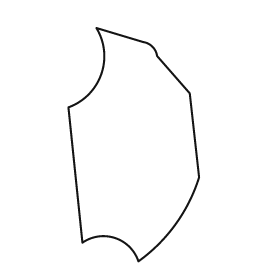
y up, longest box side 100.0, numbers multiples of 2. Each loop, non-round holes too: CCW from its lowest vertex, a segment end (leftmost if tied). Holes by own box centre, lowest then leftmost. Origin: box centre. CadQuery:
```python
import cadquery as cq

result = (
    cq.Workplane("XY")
    .moveTo(2.0, -50.0)
    .threePointArc((18.0, -34.0), (28.0, -14.0))
    .lineTo(24.0, 22.0)
    .lineTo(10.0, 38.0)
    .threePointArc((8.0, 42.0), (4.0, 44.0))
    .lineTo(-16.0, 50.0)
    .threePointArc((-14.0, 30.0), (-28.0, 16.0))
    .lineTo(-22.0, -42.0)
    .threePointArc((-8.0, -40.0), (2.0, -50.0))
    .close()
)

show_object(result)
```